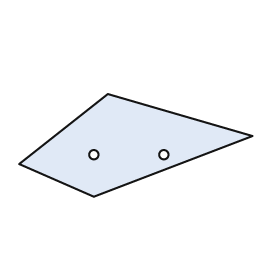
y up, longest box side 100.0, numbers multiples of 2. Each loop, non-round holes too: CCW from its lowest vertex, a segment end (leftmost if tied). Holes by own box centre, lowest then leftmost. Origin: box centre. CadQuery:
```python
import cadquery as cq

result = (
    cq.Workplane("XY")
    .moveTo(-18.0, -22.0)
    .lineTo(50.0, 4.0)
    .lineTo(-12.0, 22.0)
    .lineTo(-50.0, -8.0)
    .close()
    .moveTo(-18.0, -4.0)
    .circle(2.0)
    .moveTo(12.0, -4.0)
    .circle(2.0)
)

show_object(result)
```